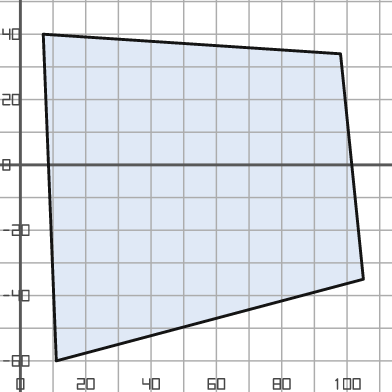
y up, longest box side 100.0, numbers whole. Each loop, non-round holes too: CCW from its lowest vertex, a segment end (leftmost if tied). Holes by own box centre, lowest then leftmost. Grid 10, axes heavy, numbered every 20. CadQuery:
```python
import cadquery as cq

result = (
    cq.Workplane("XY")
    .moveTo(11.0, -60.0)
    .lineTo(105.0, -35.0)
    .lineTo(98.0, 34.0)
    .lineTo(7.0, 40.0)
    .close()
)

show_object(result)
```